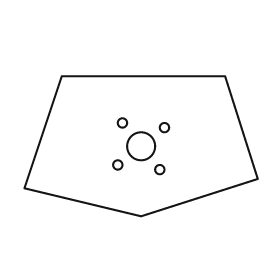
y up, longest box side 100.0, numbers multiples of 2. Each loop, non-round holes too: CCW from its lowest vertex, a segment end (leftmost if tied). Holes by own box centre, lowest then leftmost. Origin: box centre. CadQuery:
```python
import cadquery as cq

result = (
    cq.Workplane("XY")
    .moveTo(0.0, -30.0)
    .lineTo(50.0, -14.0)
    .lineTo(36.0, 30.0)
    .lineTo(-34.0, 30.0)
    .lineTo(-50.0, -18.0)
    .close()
    .moveTo(8.0, -10.0)
    .circle(2.0)
    .moveTo(-10.0, -8.0)
    .circle(2.0)
    .moveTo(0.0, 0.0)
    .circle(6.0)
    .moveTo(10.0, 8.0)
    .circle(2.0)
    .moveTo(-8.0, 10.0)
    .circle(2.0)
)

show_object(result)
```